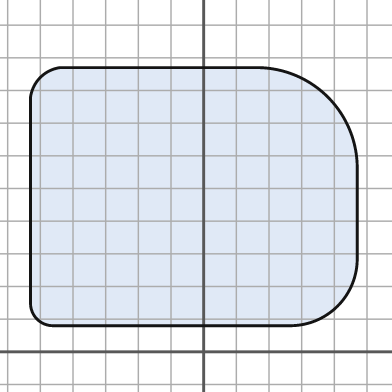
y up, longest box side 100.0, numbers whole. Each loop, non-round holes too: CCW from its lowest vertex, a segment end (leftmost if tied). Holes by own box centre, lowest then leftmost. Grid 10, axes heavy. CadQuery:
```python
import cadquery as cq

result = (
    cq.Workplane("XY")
    .moveTo(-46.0, 8.0)
    .lineTo(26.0, 8.0)
    .threePointArc((41.0, 14.0), (47.0, 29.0))
    .lineTo(47.0, 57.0)
    .threePointArc((38.0, 78.0), (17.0, 87.0))
    .lineTo(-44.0, 87.0)
    .threePointArc((-50.0, 84.0), (-53.0, 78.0))
    .lineTo(-53.0, 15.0)
    .threePointArc((-51.0, 10.0), (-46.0, 8.0))
    .close()
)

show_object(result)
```